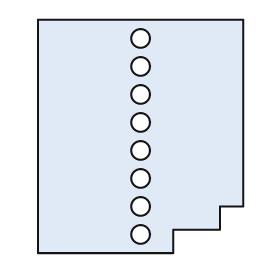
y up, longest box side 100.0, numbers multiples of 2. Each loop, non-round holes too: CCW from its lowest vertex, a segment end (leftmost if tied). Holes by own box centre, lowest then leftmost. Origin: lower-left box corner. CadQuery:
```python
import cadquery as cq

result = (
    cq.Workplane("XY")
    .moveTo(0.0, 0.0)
    .lineTo(58.0, 0.0)
    .lineTo(58.0, 10.0)
    .lineTo(78.0, 10.0)
    .lineTo(78.0, 20.0)
    .lineTo(88.0, 20.0)
    .lineTo(88.0, 100.0)
    .lineTo(0.0, 100.0)
    .close()
    .moveTo(44.0, 8.0)
    .circle(4.0)
    .moveTo(44.0, 20.0)
    .circle(4.0)
    .moveTo(44.0, 32.0)
    .circle(4.0)
    .moveTo(44.0, 44.0)
    .circle(4.0)
    .moveTo(44.0, 56.0)
    .circle(4.0)
    .moveTo(44.0, 68.0)
    .circle(4.0)
    .moveTo(44.0, 80.0)
    .circle(4.0)
    .moveTo(44.0, 92.0)
    .circle(4.0)
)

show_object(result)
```